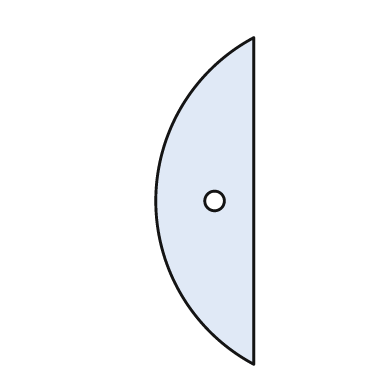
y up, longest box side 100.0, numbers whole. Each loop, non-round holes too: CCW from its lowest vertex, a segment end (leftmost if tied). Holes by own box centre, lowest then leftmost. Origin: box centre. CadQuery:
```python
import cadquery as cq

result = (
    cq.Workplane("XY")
    .moveTo(15.0, -50.0)
    .lineTo(15.0, 50.0)
    .threePointArc((-15.0, 0.0), (15.0, -50.0))
    .close()
    .moveTo(3.0, 0.0)
    .circle(3.0)
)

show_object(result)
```